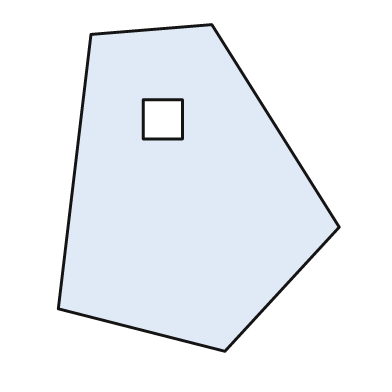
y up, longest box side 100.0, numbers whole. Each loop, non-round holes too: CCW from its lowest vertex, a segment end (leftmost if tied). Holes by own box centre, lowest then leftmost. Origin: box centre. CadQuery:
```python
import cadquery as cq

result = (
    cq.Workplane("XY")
    .moveTo(8.0, -50.0)
    .lineTo(43.0, -12.0)
    .lineTo(4.0, 50.0)
    .lineTo(-33.0, 47.0)
    .lineTo(-43.0, -37.0)
    .close()
    .moveTo(-17.0, 15.0)
    .lineTo(-5.0, 15.0)
    .lineTo(-5.0, 27.0)
    .lineTo(-17.0, 27.0)
    .close()
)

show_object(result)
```